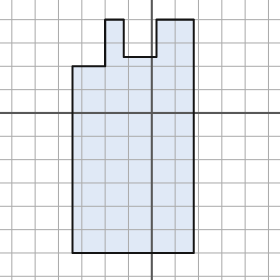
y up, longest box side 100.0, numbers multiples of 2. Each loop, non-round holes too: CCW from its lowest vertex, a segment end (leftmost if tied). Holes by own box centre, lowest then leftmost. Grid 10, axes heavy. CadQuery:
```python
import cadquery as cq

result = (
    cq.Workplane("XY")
    .moveTo(-34.0, -60.0)
    .lineTo(18.0, -60.0)
    .lineTo(18.0, 40.0)
    .lineTo(2.0, 40.0)
    .lineTo(2.0, 24.0)
    .lineTo(-12.0, 24.0)
    .lineTo(-12.0, 40.0)
    .lineTo(-20.0, 40.0)
    .lineTo(-20.0, 20.0)
    .lineTo(-34.0, 20.0)
    .close()
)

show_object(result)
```